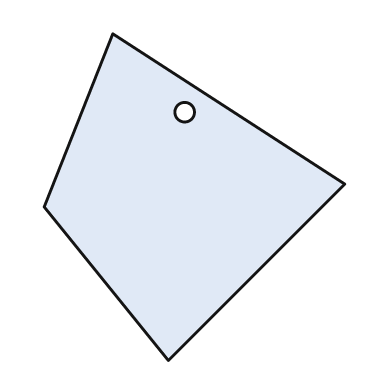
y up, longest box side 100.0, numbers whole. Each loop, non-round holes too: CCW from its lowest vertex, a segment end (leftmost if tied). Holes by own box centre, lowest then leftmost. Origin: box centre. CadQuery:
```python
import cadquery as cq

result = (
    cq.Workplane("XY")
    .moveTo(-8.0, -50.0)
    .lineTo(46.0, 4.0)
    .lineTo(-25.0, 50.0)
    .lineTo(-46.0, -3.0)
    .close()
    .moveTo(-3.0, 26.0)
    .circle(3.0)
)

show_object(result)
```